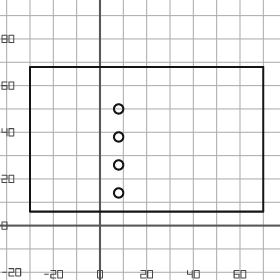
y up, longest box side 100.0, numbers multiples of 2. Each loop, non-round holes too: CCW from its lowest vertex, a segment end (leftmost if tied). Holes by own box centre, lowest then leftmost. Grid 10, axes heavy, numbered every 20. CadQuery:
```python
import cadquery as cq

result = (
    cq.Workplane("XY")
    .moveTo(-30.0, 6.0)
    .lineTo(70.0, 6.0)
    .lineTo(70.0, 68.0)
    .lineTo(-30.0, 68.0)
    .close()
    .moveTo(8.0, 14.0)
    .circle(2.0)
    .moveTo(8.0, 26.0)
    .circle(2.0)
    .moveTo(8.0, 38.0)
    .circle(2.0)
    .moveTo(8.0, 50.0)
    .circle(2.0)
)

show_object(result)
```